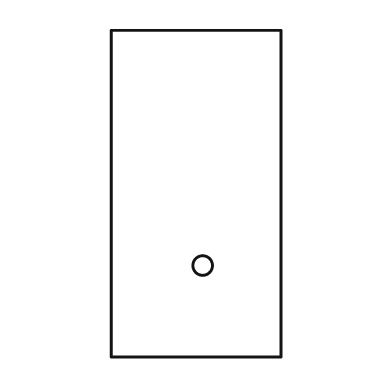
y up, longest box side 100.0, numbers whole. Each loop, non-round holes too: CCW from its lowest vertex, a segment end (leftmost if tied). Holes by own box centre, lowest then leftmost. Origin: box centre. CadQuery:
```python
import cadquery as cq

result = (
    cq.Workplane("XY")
    .moveTo(-26.0, -50.0)
    .lineTo(26.0, -50.0)
    .lineTo(26.0, 50.0)
    .lineTo(-26.0, 50.0)
    .close()
    .moveTo(2.0, -22.0)
    .circle(3.0)
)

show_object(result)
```